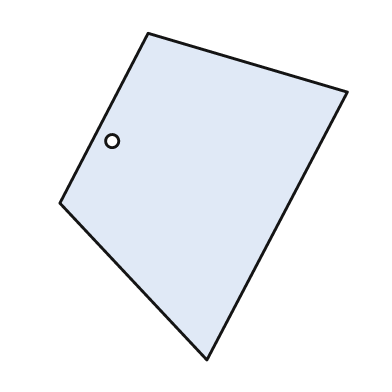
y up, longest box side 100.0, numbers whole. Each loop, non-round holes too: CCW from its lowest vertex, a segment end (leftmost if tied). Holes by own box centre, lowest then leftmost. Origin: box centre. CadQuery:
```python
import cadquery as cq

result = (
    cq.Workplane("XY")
    .moveTo(1.0, -50.0)
    .lineTo(44.0, 32.0)
    .lineTo(-17.0, 50.0)
    .lineTo(-44.0, -2.0)
    .close()
    .moveTo(-28.0, 17.0)
    .circle(2.0)
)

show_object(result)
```